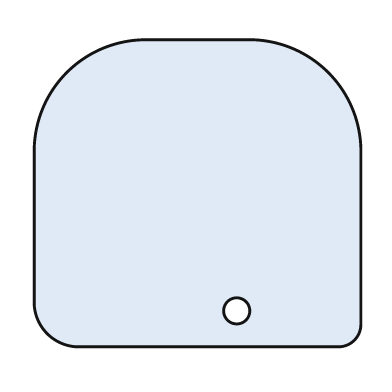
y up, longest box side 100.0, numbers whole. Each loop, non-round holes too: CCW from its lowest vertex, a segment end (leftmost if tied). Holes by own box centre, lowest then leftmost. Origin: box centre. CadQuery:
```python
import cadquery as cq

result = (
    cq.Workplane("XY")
    .moveTo(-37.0, -47.0)
    .lineTo(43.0, -47.0)
    .threePointArc((48.0, -45.0), (50.0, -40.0))
    .lineTo(50.0, 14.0)
    .threePointArc((40.0, 37.0), (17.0, 47.0))
    .lineTo(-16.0, 47.0)
    .threePointArc((-40.0, 37.0), (-50.0, 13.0))
    .lineTo(-50.0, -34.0)
    .threePointArc((-46.0, -43.0), (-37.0, -47.0))
    .close()
    .moveTo(12.0, -36.0)
    .circle(4.0)
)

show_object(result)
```